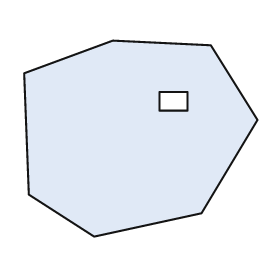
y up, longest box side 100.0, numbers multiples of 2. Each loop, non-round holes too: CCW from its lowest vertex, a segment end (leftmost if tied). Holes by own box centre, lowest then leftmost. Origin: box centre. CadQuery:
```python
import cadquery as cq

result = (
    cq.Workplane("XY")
    .moveTo(-20.0, -42.0)
    .lineTo(26.0, -32.0)
    .lineTo(50.0, 8.0)
    .lineTo(30.0, 40.0)
    .lineTo(-12.0, 42.0)
    .lineTo(-50.0, 28.0)
    .lineTo(-48.0, -24.0)
    .close()
    .moveTo(8.0, 12.0)
    .lineTo(20.0, 12.0)
    .lineTo(20.0, 20.0)
    .lineTo(8.0, 20.0)
    .close()
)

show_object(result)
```